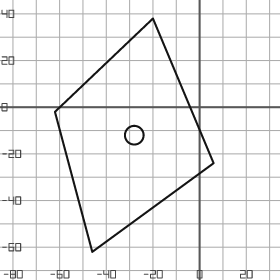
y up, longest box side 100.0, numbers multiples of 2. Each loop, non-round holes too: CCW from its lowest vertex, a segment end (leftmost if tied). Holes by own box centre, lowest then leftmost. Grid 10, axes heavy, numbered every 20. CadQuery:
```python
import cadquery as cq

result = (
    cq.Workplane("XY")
    .moveTo(-46.0, -62.0)
    .lineTo(6.0, -24.0)
    .lineTo(-20.0, 38.0)
    .lineTo(-62.0, -2.0)
    .close()
    .moveTo(-28.0, -12.0)
    .circle(4.0)
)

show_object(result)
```